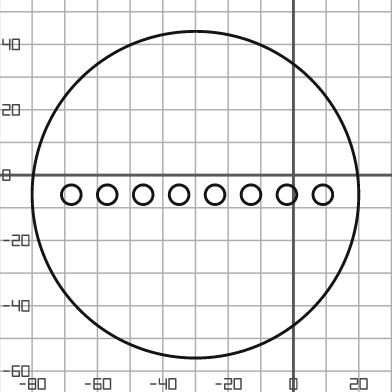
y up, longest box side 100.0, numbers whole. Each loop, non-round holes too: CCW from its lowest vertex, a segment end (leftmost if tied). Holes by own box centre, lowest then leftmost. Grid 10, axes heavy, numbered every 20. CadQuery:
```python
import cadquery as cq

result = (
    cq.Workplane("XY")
    .moveTo(-30.0, -6.0)
    .circle(50.0)
    .moveTo(-68.0, -6.0)
    .circle(3.0)
    .moveTo(-57.0, -6.0)
    .circle(3.0)
    .moveTo(-46.0, -6.0)
    .circle(3.0)
    .moveTo(-35.0, -6.0)
    .circle(3.0)
    .moveTo(-24.0, -6.0)
    .circle(3.0)
    .moveTo(-13.0, -6.0)
    .circle(3.0)
    .moveTo(-2.0, -6.0)
    .circle(3.0)
    .moveTo(9.0, -6.0)
    .circle(3.0)
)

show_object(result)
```